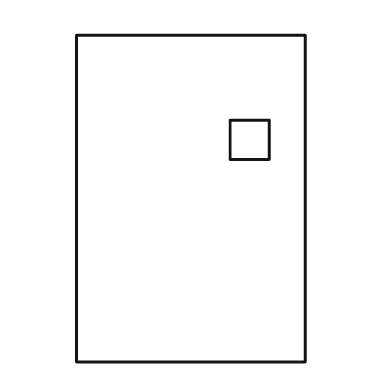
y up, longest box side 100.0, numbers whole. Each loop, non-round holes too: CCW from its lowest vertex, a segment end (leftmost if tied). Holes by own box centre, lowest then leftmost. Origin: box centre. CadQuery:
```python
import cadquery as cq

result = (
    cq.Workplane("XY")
    .moveTo(-35.0, -50.0)
    .lineTo(35.0, -50.0)
    .lineTo(35.0, 50.0)
    .lineTo(-35.0, 50.0)
    .close()
    .moveTo(12.0, 12.0)
    .lineTo(24.0, 12.0)
    .lineTo(24.0, 24.0)
    .lineTo(12.0, 24.0)
    .close()
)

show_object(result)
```